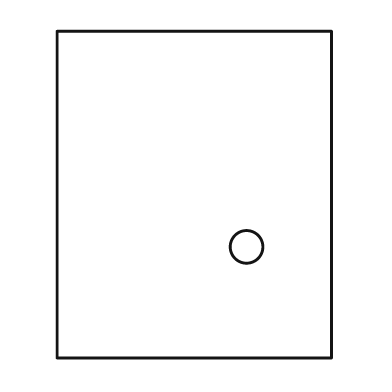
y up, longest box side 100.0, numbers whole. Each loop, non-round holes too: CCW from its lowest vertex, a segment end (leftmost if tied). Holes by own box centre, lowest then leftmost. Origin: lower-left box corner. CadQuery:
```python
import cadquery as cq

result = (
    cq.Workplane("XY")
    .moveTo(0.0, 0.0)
    .lineTo(84.0, 0.0)
    .lineTo(84.0, 100.0)
    .lineTo(0.0, 100.0)
    .close()
    .moveTo(58.0, 34.0)
    .circle(5.0)
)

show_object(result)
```